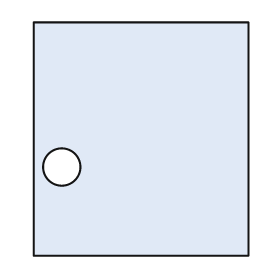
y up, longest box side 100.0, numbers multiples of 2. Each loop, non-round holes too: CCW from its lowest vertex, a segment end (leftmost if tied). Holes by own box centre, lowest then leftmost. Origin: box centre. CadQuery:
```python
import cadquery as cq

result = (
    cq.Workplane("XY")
    .moveTo(-46.0, -50.0)
    .lineTo(46.0, -50.0)
    .lineTo(46.0, 50.0)
    .lineTo(-46.0, 50.0)
    .close()
    .moveTo(-34.0, -12.0)
    .circle(8.0)
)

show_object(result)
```